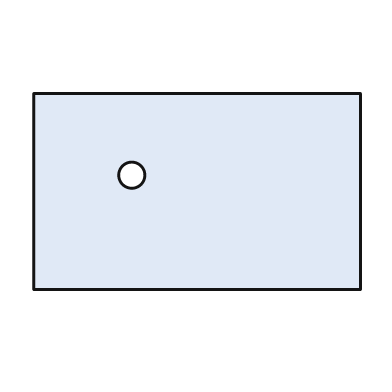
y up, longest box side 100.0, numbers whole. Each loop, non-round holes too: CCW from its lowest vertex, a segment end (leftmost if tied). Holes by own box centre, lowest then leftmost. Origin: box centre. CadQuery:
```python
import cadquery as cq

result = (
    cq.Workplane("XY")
    .moveTo(-50.0, -30.0)
    .lineTo(50.0, -30.0)
    .lineTo(50.0, 30.0)
    .lineTo(-50.0, 30.0)
    .close()
    .moveTo(-20.0, 5.0)
    .circle(4.0)
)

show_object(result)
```